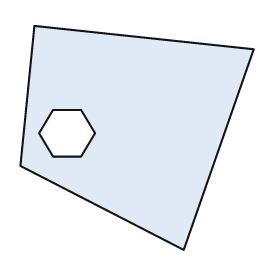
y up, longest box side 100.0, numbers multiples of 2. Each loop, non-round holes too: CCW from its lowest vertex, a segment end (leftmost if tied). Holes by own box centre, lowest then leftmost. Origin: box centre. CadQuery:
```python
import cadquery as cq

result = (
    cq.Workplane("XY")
    .moveTo(20.0, -48.0)
    .lineTo(50.0, 38.0)
    .lineTo(-44.0, 48.0)
    .lineTo(-50.0, -12.0)
    .close()
    .moveTo(-36.0, -8.0)
    .lineTo(-24.0, -8.0)
    .lineTo(-18.0, 2.0)
    .lineTo(-24.0, 12.0)
    .lineTo(-36.0, 12.0)
    .lineTo(-42.0, 2.0)
    .close()
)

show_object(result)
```